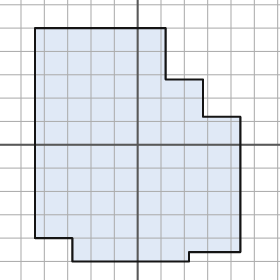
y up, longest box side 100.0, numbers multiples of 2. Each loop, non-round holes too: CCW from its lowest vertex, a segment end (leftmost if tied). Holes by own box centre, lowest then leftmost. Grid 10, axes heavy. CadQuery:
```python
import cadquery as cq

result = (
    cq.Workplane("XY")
    .moveTo(-28.0, -50.0)
    .lineTo(22.0, -50.0)
    .lineTo(22.0, -46.0)
    .lineTo(44.0, -46.0)
    .lineTo(44.0, 12.0)
    .lineTo(28.0, 12.0)
    .lineTo(28.0, 28.0)
    .lineTo(12.0, 28.0)
    .lineTo(12.0, 50.0)
    .lineTo(-44.0, 50.0)
    .lineTo(-44.0, -40.0)
    .lineTo(-28.0, -40.0)
    .close()
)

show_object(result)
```